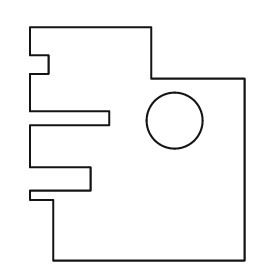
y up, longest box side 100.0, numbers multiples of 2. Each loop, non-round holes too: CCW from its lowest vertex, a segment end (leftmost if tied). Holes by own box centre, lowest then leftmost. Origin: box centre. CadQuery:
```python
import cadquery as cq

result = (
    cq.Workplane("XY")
    .moveTo(-36.0, -50.0)
    .lineTo(46.0, -50.0)
    .lineTo(46.0, 28.0)
    .lineTo(6.0, 28.0)
    .lineTo(6.0, 50.0)
    .lineTo(-46.0, 50.0)
    .lineTo(-46.0, 38.0)
    .lineTo(-38.0, 38.0)
    .lineTo(-38.0, 30.0)
    .lineTo(-46.0, 30.0)
    .lineTo(-46.0, 14.0)
    .lineTo(-12.0, 14.0)
    .lineTo(-12.0, 8.0)
    .lineTo(-46.0, 8.0)
    .lineTo(-46.0, -10.0)
    .lineTo(-20.0, -10.0)
    .lineTo(-20.0, -20.0)
    .lineTo(-46.0, -20.0)
    .lineTo(-46.0, -24.0)
    .lineTo(-36.0, -24.0)
    .close()
    .moveTo(16.0, 10.0)
    .circle(12.0)
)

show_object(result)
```